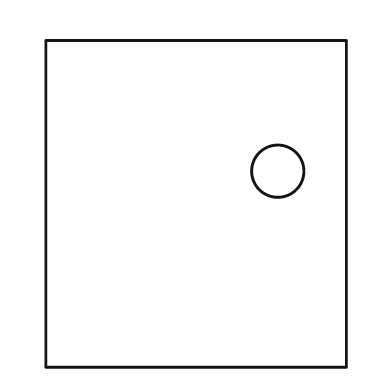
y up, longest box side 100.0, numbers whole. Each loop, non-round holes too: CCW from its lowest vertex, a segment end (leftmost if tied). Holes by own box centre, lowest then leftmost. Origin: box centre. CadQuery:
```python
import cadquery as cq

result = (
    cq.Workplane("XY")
    .moveTo(-46.0, -50.0)
    .lineTo(46.0, -50.0)
    .lineTo(46.0, 50.0)
    .lineTo(-46.0, 50.0)
    .close()
    .moveTo(25.0, 10.0)
    .circle(8.0)
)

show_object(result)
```